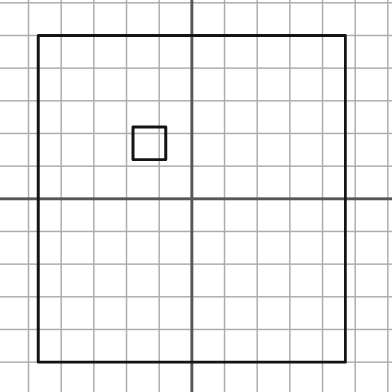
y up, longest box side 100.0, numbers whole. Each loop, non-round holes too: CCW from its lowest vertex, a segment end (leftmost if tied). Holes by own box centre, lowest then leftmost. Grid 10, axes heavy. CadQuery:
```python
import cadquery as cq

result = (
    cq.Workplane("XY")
    .moveTo(-47.0, -50.0)
    .lineTo(47.0, -50.0)
    .lineTo(47.0, 50.0)
    .lineTo(-47.0, 50.0)
    .close()
    .moveTo(-18.0, 12.0)
    .lineTo(-8.0, 12.0)
    .lineTo(-8.0, 22.0)
    .lineTo(-18.0, 22.0)
    .close()
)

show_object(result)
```